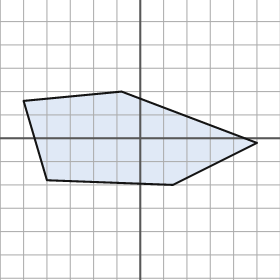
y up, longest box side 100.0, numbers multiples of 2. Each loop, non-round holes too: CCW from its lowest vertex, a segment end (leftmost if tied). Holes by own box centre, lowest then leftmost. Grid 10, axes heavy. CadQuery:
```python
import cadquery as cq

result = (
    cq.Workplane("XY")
    .moveTo(14.0, -20.0)
    .lineTo(50.0, -2.0)
    .lineTo(-8.0, 20.0)
    .lineTo(-50.0, 16.0)
    .lineTo(-40.0, -18.0)
    .close()
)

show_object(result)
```